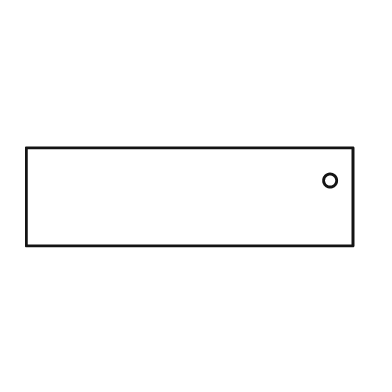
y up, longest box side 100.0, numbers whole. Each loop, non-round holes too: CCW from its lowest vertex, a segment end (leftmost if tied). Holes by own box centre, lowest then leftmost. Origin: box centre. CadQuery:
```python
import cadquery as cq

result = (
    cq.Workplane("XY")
    .moveTo(-50.0, -15.0)
    .lineTo(50.0, -15.0)
    .lineTo(50.0, 15.0)
    .lineTo(-50.0, 15.0)
    .close()
    .moveTo(43.0, 5.0)
    .circle(2.0)
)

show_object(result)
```